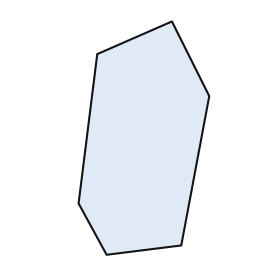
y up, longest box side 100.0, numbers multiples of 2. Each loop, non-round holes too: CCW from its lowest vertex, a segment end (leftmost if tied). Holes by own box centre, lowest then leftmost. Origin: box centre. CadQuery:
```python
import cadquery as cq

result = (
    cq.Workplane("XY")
    .moveTo(-16.0, -50.0)
    .lineTo(16.0, -46.0)
    .lineTo(28.0, 18.0)
    .lineTo(12.0, 50.0)
    .lineTo(-20.0, 36.0)
    .lineTo(-28.0, -28.0)
    .close()
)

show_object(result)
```